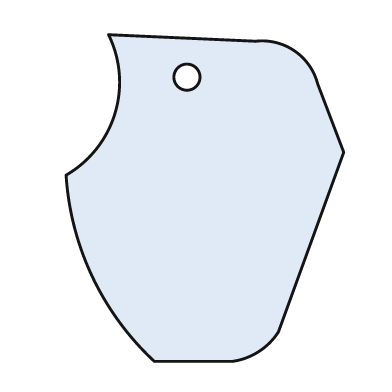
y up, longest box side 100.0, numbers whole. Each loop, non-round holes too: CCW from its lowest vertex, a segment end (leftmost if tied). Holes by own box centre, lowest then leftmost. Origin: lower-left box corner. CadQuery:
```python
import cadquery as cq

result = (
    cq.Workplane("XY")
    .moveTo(27.0, 0.0)
    .lineTo(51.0, 0.0)
    .threePointArc((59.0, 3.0), (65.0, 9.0))
    .lineTo(85.0, 64.0)
    .lineTo(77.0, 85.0)
    .threePointArc((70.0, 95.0), (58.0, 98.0))
    .lineTo(13.0, 100.0)
    .threePointArc((15.0, 76.0), (0.0, 57.0))
    .threePointArc((8.0, 26.0), (27.0, 0.0))
    .close()
    .moveTo(37.0, 87.0)
    .circle(4.0)
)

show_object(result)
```